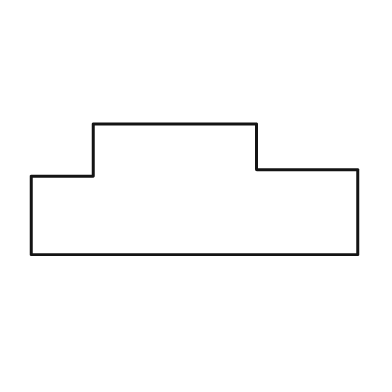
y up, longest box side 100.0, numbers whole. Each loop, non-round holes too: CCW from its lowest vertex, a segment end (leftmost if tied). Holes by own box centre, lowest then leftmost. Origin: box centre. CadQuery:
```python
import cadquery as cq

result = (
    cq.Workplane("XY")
    .moveTo(-50.0, -20.0)
    .lineTo(50.0, -20.0)
    .lineTo(50.0, 6.0)
    .lineTo(19.0, 6.0)
    .lineTo(19.0, 20.0)
    .lineTo(-31.0, 20.0)
    .lineTo(-31.0, 4.0)
    .lineTo(-50.0, 4.0)
    .close()
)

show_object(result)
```